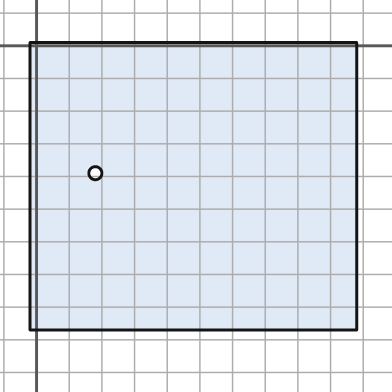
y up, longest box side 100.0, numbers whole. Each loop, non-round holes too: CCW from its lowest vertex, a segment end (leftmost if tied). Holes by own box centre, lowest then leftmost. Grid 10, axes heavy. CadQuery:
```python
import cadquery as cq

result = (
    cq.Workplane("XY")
    .moveTo(-2.0, -87.0)
    .lineTo(98.0, -87.0)
    .lineTo(98.0, 1.0)
    .lineTo(-2.0, 1.0)
    .close()
    .moveTo(18.0, -39.0)
    .circle(2.0)
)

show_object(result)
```